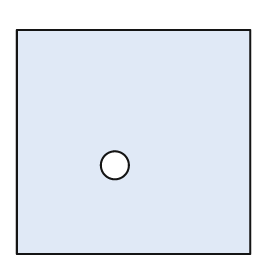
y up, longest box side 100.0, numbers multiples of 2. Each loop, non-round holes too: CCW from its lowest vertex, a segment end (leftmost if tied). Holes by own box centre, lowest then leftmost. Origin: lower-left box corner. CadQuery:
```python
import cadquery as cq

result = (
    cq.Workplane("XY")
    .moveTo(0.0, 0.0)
    .lineTo(100.0, 0.0)
    .lineTo(100.0, 96.0)
    .lineTo(0.0, 96.0)
    .close()
    .moveTo(42.0, 38.0)
    .circle(6.0)
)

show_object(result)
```